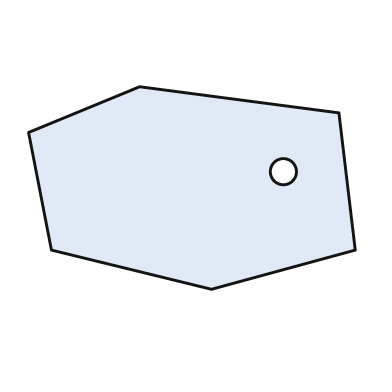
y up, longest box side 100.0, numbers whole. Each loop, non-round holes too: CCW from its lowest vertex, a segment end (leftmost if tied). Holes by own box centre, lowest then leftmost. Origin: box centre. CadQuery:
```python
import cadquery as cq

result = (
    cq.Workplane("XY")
    .moveTo(6.0, -31.0)
    .lineTo(50.0, -19.0)
    .lineTo(45.0, 23.0)
    .lineTo(-16.0, 31.0)
    .lineTo(-50.0, 17.0)
    .lineTo(-43.0, -19.0)
    .close()
    .moveTo(28.0, 5.0)
    .circle(4.0)
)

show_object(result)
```